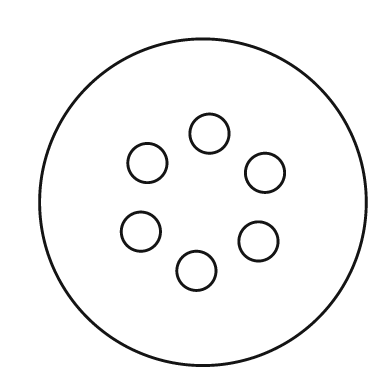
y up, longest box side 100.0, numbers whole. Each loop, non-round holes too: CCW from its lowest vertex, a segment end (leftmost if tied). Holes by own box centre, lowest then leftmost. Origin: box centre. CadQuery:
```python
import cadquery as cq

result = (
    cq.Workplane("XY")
    .moveTo(0.0, 0.0)
    .circle(50.0)
    .moveTo(-2.0, -21.0)
    .circle(6.0)
    .moveTo(17.0, -12.0)
    .circle(6.0)
    .moveTo(-19.0, -9.0)
    .circle(6.0)
    .moveTo(19.0, 9.0)
    .circle(6.0)
    .moveTo(-17.0, 12.0)
    .circle(6.0)
    .moveTo(2.0, 21.0)
    .circle(6.0)
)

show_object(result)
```